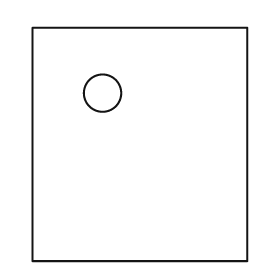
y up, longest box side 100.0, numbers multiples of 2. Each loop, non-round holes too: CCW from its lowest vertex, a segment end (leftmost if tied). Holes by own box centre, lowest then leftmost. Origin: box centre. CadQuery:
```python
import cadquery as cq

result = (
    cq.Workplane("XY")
    .moveTo(-46.0, -50.0)
    .lineTo(46.0, -50.0)
    .lineTo(46.0, 50.0)
    .lineTo(-46.0, 50.0)
    .close()
    .moveTo(-16.0, 22.0)
    .circle(8.0)
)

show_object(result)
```